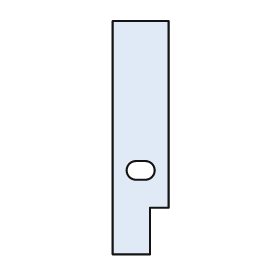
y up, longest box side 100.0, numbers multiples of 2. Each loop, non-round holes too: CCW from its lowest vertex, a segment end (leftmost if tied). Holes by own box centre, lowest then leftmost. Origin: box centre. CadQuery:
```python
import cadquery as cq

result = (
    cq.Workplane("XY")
    .moveTo(-12.0, -50.0)
    .lineTo(4.0, -50.0)
    .lineTo(4.0, -30.0)
    .lineTo(12.0, -30.0)
    .lineTo(12.0, 50.0)
    .lineTo(-12.0, 50.0)
    .close()
    .moveTo(-2.0, -18.0)
    .lineTo(2.0, -18.0)
    .threePointArc((6.0, -14.0), (2.0, -10.0))
    .lineTo(-2.0, -10.0)
    .threePointArc((-6.0, -14.0), (-2.0, -18.0))
    .close()
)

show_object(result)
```